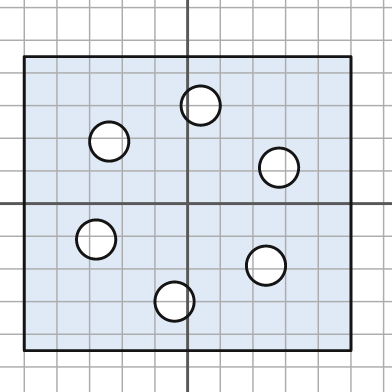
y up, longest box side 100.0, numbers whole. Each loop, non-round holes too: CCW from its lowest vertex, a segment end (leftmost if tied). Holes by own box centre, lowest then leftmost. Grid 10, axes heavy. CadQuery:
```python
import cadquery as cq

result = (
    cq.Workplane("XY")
    .moveTo(-50.0, -45.0)
    .lineTo(50.0, -45.0)
    .lineTo(50.0, 45.0)
    .lineTo(-50.0, 45.0)
    .close()
    .moveTo(-4.0, -30.0)
    .circle(6.0)
    .moveTo(24.0, -19.0)
    .circle(6.0)
    .moveTo(-28.0, -11.0)
    .circle(6.0)
    .moveTo(28.0, 11.0)
    .circle(6.0)
    .moveTo(-24.0, 19.0)
    .circle(6.0)
    .moveTo(4.0, 30.0)
    .circle(6.0)
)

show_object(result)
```